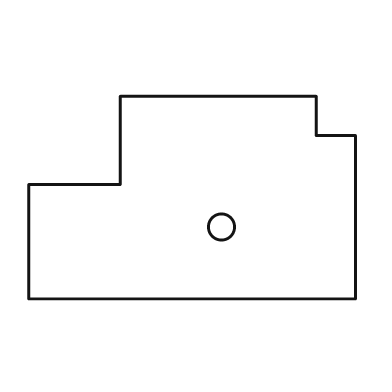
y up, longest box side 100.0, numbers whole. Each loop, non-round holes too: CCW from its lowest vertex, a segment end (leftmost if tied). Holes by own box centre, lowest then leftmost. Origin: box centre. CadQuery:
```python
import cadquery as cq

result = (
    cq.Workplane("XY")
    .moveTo(-50.0, -31.0)
    .lineTo(50.0, -31.0)
    .lineTo(50.0, 19.0)
    .lineTo(38.0, 19.0)
    .lineTo(38.0, 31.0)
    .lineTo(-22.0, 31.0)
    .lineTo(-22.0, 4.0)
    .lineTo(-50.0, 4.0)
    .close()
    .moveTo(9.0, -9.0)
    .circle(4.0)
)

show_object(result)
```